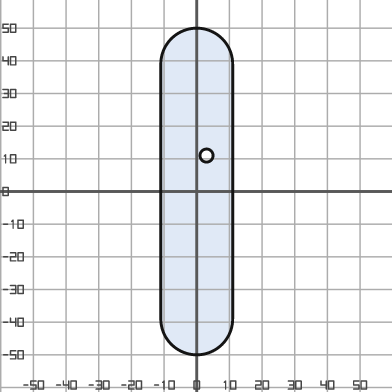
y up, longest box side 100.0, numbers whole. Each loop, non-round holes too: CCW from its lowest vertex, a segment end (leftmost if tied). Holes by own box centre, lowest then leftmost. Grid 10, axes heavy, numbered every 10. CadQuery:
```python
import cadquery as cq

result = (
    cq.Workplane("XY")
    .moveTo(-11.0, -39.0)
    .threePointArc((0.0, -50.0), (11.0, -39.0))
    .lineTo(11.0, 39.0)
    .threePointArc((0.0, 50.0), (-11.0, 39.0))
    .close()
    .moveTo(3.0, 11.0)
    .circle(2.0)
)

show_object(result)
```